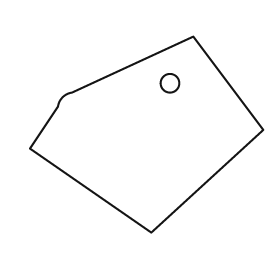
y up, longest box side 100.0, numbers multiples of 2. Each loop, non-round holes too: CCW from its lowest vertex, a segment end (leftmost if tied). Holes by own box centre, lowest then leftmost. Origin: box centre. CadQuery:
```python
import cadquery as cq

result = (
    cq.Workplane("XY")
    .moveTo(2.0, -42.0)
    .lineTo(50.0, 2.0)
    .lineTo(20.0, 42.0)
    .lineTo(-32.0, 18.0)
    .threePointArc((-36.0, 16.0), (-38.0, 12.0))
    .lineTo(-50.0, -6.0)
    .close()
    .moveTo(10.0, 22.0)
    .circle(4.0)
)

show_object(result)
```